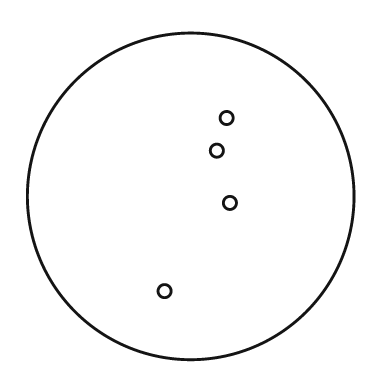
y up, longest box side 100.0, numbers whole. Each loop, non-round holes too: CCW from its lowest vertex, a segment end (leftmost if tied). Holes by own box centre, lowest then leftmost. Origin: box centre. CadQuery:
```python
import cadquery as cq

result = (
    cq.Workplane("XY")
    .moveTo(0.0, 0.0)
    .circle(50.0)
    .moveTo(-8.0, -29.0)
    .circle(2.0)
    .moveTo(12.0, -2.0)
    .circle(2.0)
    .moveTo(8.0, 14.0)
    .circle(2.0)
    .moveTo(11.0, 24.0)
    .circle(2.0)
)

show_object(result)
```